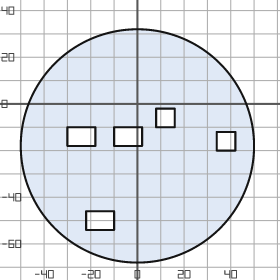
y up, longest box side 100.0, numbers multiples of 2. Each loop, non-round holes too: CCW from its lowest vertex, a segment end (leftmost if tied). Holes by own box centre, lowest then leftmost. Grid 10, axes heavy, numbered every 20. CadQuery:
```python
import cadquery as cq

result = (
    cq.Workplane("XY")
    .moveTo(0.0, -18.0)
    .circle(50.0)
    .moveTo(-22.0, -54.0)
    .lineTo(-10.0, -54.0)
    .lineTo(-10.0, -46.0)
    .lineTo(-22.0, -46.0)
    .close()
    .moveTo(34.0, -20.0)
    .lineTo(42.0, -20.0)
    .lineTo(42.0, -12.0)
    .lineTo(34.0, -12.0)
    .close()
    .moveTo(-30.0, -18.0)
    .lineTo(-18.0, -18.0)
    .lineTo(-18.0, -10.0)
    .lineTo(-30.0, -10.0)
    .close()
    .moveTo(-10.0, -18.0)
    .lineTo(2.0, -18.0)
    .lineTo(2.0, -10.0)
    .lineTo(-10.0, -10.0)
    .close()
    .moveTo(8.0, -10.0)
    .lineTo(16.0, -10.0)
    .lineTo(16.0, -2.0)
    .lineTo(8.0, -2.0)
    .close()
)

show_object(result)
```